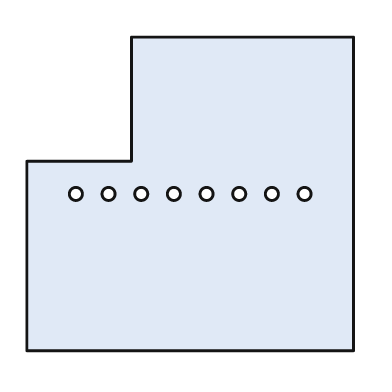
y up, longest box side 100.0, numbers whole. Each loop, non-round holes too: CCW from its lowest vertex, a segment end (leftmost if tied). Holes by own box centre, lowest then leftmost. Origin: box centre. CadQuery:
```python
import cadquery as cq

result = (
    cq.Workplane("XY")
    .moveTo(-50.0, -48.0)
    .lineTo(50.0, -48.0)
    .lineTo(50.0, 48.0)
    .lineTo(-18.0, 48.0)
    .lineTo(-18.0, 10.0)
    .lineTo(-50.0, 10.0)
    .close()
    .moveTo(-35.0, 0.0)
    .circle(2.0)
    .moveTo(-25.0, 0.0)
    .circle(2.0)
    .moveTo(-15.0, 0.0)
    .circle(2.0)
    .moveTo(-5.0, 0.0)
    .circle(2.0)
    .moveTo(5.0, 0.0)
    .circle(2.0)
    .moveTo(15.0, 0.0)
    .circle(2.0)
    .moveTo(25.0, 0.0)
    .circle(2.0)
    .moveTo(35.0, 0.0)
    .circle(2.0)
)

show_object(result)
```